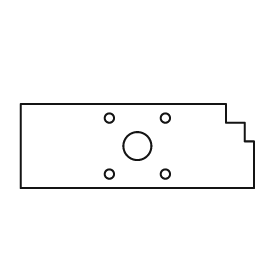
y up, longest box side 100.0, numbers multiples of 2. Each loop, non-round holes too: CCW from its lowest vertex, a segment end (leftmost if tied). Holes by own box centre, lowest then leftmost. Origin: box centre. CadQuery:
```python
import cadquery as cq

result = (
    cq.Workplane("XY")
    .moveTo(-50.0, -18.0)
    .lineTo(50.0, -18.0)
    .lineTo(50.0, 2.0)
    .lineTo(46.0, 2.0)
    .lineTo(46.0, 10.0)
    .lineTo(38.0, 10.0)
    .lineTo(38.0, 18.0)
    .lineTo(-50.0, 18.0)
    .close()
    .moveTo(-12.0, -12.0)
    .circle(2.0)
    .moveTo(12.0, -12.0)
    .circle(2.0)
    .moveTo(0.0, 0.0)
    .circle(6.0)
    .moveTo(-12.0, 12.0)
    .circle(2.0)
    .moveTo(12.0, 12.0)
    .circle(2.0)
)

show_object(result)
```